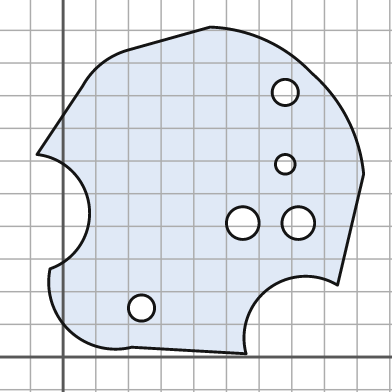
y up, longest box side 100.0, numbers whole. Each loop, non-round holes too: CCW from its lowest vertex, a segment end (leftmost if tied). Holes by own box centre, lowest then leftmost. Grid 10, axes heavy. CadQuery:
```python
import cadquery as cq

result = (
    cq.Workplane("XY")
    .moveTo(56.0, 1.0)
    .threePointArc((63.0, 21.0), (84.0, 22.0))
    .lineTo(92.0, 56.0)
    .threePointArc((87.0, 73.0), (76.0, 87.0))
    .threePointArc((62.0, 97.0), (45.0, 101.0))
    .lineTo(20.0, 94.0)
    .threePointArc((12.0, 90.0), (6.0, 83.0))
    .lineTo(-8.0, 62.0)
    .threePointArc((8.0, 46.0), (-4.0, 27.0))
    .threePointArc((2.0, 8.0), (21.0, 3.0))
    .close()
    .moveTo(24.0, 15.0)
    .circle(4.0)
    .moveTo(55.0, 41.0)
    .circle(5.0)
    .moveTo(72.0, 41.0)
    .circle(5.0)
    .moveTo(68.0, 59.0)
    .circle(3.0)
    .moveTo(68.0, 81.0)
    .circle(4.0)
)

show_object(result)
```